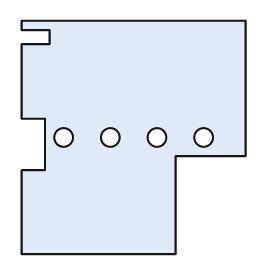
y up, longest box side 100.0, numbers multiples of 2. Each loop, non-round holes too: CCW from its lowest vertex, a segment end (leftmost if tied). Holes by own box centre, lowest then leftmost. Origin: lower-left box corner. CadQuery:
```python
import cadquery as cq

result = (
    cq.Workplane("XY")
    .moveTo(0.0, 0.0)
    .lineTo(66.0, 0.0)
    .lineTo(66.0, 42.0)
    .lineTo(96.0, 42.0)
    .lineTo(96.0, 100.0)
    .lineTo(0.0, 100.0)
    .lineTo(0.0, 96.0)
    .lineTo(12.0, 96.0)
    .lineTo(12.0, 90.0)
    .lineTo(0.0, 90.0)
    .lineTo(0.0, 58.0)
    .lineTo(10.0, 58.0)
    .lineTo(10.0, 36.0)
    .lineTo(0.0, 36.0)
    .close()
    .moveTo(18.0, 50.0)
    .circle(4.0)
    .moveTo(38.0, 50.0)
    .circle(4.0)
    .moveTo(58.0, 50.0)
    .circle(4.0)
    .moveTo(78.0, 50.0)
    .circle(4.0)
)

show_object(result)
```